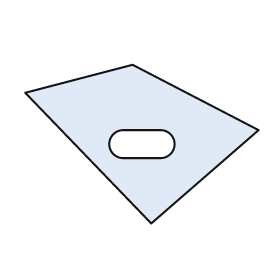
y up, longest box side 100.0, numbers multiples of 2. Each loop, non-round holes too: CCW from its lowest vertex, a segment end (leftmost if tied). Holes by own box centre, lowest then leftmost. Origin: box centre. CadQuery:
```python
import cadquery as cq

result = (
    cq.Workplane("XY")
    .moveTo(4.0, -34.0)
    .lineTo(50.0, 6.0)
    .lineTo(-4.0, 34.0)
    .lineTo(-50.0, 22.0)
    .close()
    .moveTo(-8.0, -6.0)
    .lineTo(8.0, -6.0)
    .threePointArc((14.0, 0.0), (8.0, 6.0))
    .lineTo(-8.0, 6.0)
    .threePointArc((-14.0, 0.0), (-8.0, -6.0))
    .close()
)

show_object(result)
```